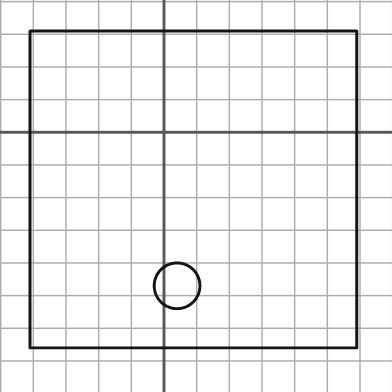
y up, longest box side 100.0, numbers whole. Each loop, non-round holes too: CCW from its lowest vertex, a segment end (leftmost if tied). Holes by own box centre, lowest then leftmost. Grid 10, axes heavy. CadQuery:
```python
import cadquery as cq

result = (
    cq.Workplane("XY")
    .moveTo(-41.0, -66.0)
    .lineTo(59.0, -66.0)
    .lineTo(59.0, 31.0)
    .lineTo(-41.0, 31.0)
    .close()
    .moveTo(4.0, -47.0)
    .circle(7.0)
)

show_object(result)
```